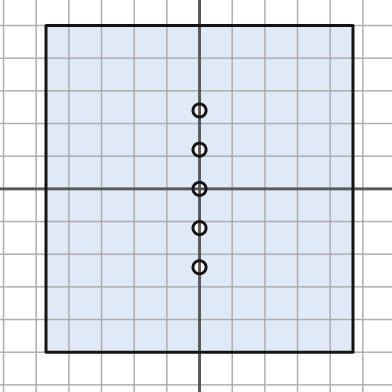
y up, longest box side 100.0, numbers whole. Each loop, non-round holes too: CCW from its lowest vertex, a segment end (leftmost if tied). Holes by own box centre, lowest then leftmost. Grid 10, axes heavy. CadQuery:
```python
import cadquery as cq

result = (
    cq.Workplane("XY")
    .moveTo(-47.0, -50.0)
    .lineTo(47.0, -50.0)
    .lineTo(47.0, 50.0)
    .lineTo(-47.0, 50.0)
    .close()
    .moveTo(0.0, -24.0)
    .circle(2.0)
    .moveTo(0.0, -12.0)
    .circle(2.0)
    .moveTo(0.0, 0.0)
    .circle(2.0)
    .moveTo(0.0, 12.0)
    .circle(2.0)
    .moveTo(0.0, 24.0)
    .circle(2.0)
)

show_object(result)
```